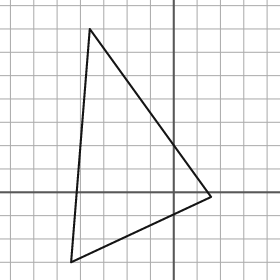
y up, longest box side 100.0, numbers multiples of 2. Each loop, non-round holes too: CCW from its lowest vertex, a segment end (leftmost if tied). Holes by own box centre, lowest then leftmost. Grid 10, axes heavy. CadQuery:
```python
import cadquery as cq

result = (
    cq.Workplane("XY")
    .moveTo(-44.0, -30.0)
    .lineTo(16.0, -2.0)
    .lineTo(-36.0, 70.0)
    .close()
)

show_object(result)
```